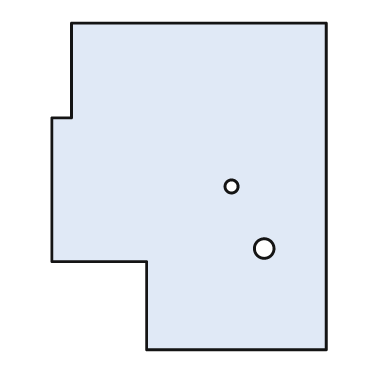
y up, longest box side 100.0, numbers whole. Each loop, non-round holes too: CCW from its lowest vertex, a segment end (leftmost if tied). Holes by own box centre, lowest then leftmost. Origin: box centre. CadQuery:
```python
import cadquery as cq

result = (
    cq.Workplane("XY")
    .moveTo(-13.0, -50.0)
    .lineTo(42.0, -50.0)
    .lineTo(42.0, 50.0)
    .lineTo(-36.0, 50.0)
    .lineTo(-36.0, 21.0)
    .lineTo(-42.0, 21.0)
    .lineTo(-42.0, -23.0)
    .lineTo(-13.0, -23.0)
    .close()
    .moveTo(23.0, -19.0)
    .circle(3.0)
    .moveTo(13.0, 0.0)
    .circle(2.0)
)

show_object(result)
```